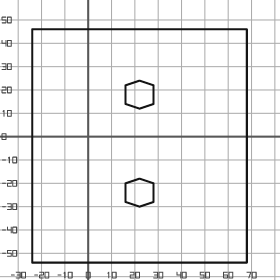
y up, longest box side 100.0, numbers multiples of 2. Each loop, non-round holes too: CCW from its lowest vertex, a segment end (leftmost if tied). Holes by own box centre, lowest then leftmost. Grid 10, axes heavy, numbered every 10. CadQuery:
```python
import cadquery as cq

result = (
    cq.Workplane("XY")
    .moveTo(-24.0, -54.0)
    .lineTo(68.0, -54.0)
    .lineTo(68.0, 46.0)
    .lineTo(-24.0, 46.0)
    .close()
    .moveTo(22.0, -30.0)
    .lineTo(28.0, -28.0)
    .lineTo(28.0, -20.0)
    .lineTo(22.0, -18.0)
    .lineTo(16.0, -20.0)
    .lineTo(16.0, -28.0)
    .close()
    .moveTo(22.0, 12.0)
    .lineTo(28.0, 14.0)
    .lineTo(28.0, 22.0)
    .lineTo(22.0, 24.0)
    .lineTo(16.0, 22.0)
    .lineTo(16.0, 14.0)
    .close()
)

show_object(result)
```